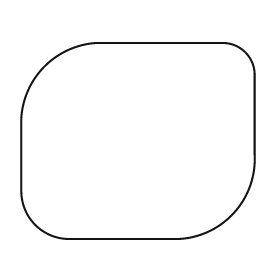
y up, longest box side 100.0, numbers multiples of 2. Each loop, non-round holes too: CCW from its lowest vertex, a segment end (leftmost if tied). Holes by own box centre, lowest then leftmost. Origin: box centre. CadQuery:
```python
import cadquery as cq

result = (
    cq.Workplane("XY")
    .moveTo(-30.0, -42.0)
    .lineTo(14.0, -42.0)
    .threePointArc((40.0, -32.0), (50.0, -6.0))
    .lineTo(50.0, 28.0)
    .threePointArc((46.0, 38.0), (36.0, 42.0))
    .lineTo(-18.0, 42.0)
    .threePointArc((-40.0, 32.0), (-50.0, 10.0))
    .lineTo(-50.0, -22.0)
    .threePointArc((-44.0, -36.0), (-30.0, -42.0))
    .close()
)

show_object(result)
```